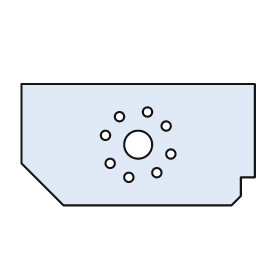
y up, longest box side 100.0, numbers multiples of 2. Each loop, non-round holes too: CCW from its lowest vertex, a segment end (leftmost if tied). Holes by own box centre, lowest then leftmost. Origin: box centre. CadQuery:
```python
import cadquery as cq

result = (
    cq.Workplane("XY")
    .moveTo(-32.0, -26.0)
    .lineTo(40.0, -26.0)
    .lineTo(44.0, -22.0)
    .lineTo(44.0, -14.0)
    .lineTo(50.0, -14.0)
    .lineTo(50.0, 26.0)
    .lineTo(-50.0, 26.0)
    .lineTo(-50.0, -8.0)
    .close()
    .moveTo(-4.0, -14.0)
    .circle(2.0)
    .moveTo(8.0, -12.0)
    .circle(2.0)
    .moveTo(-12.0, -8.0)
    .circle(2.0)
    .moveTo(14.0, -4.0)
    .circle(2.0)
    .moveTo(0.0, 0.0)
    .circle(6.0)
    .moveTo(-14.0, 4.0)
    .circle(2.0)
    .moveTo(12.0, 8.0)
    .circle(2.0)
    .moveTo(-8.0, 12.0)
    .circle(2.0)
    .moveTo(4.0, 14.0)
    .circle(2.0)
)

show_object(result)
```